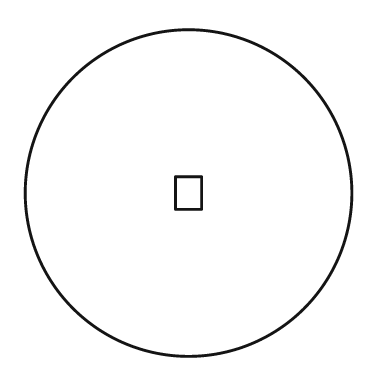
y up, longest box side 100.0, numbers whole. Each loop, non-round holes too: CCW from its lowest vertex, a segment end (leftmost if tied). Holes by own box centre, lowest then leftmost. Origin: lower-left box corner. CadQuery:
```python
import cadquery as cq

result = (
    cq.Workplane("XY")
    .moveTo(50.0, 50.0)
    .circle(50.0)
    .moveTo(46.0, 45.0)
    .lineTo(54.0, 45.0)
    .lineTo(54.0, 55.0)
    .lineTo(46.0, 55.0)
    .close()
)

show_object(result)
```